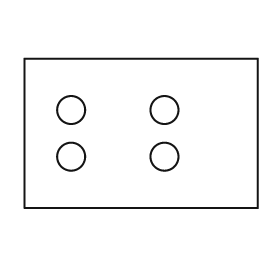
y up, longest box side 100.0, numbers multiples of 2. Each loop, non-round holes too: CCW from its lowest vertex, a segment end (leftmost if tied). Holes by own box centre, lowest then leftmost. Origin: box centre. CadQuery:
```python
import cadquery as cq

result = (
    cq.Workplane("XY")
    .moveTo(-50.0, -32.0)
    .lineTo(50.0, -32.0)
    .lineTo(50.0, 32.0)
    .lineTo(-50.0, 32.0)
    .close()
    .moveTo(-30.0, -10.0)
    .circle(6.0)
    .moveTo(10.0, -10.0)
    .circle(6.0)
    .moveTo(-30.0, 10.0)
    .circle(6.0)
    .moveTo(10.0, 10.0)
    .circle(6.0)
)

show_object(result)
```